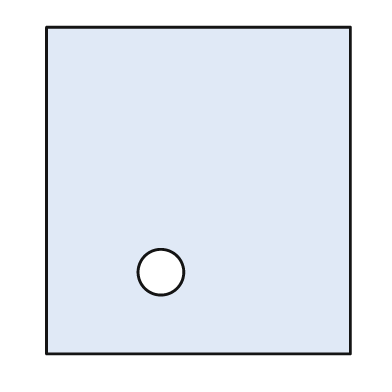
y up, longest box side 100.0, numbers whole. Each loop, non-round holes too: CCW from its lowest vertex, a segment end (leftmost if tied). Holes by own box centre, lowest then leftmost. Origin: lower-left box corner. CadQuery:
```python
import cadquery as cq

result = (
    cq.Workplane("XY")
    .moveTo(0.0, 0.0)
    .lineTo(93.0, 0.0)
    .lineTo(93.0, 100.0)
    .lineTo(0.0, 100.0)
    .close()
    .moveTo(35.0, 25.0)
    .circle(7.0)
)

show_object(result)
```